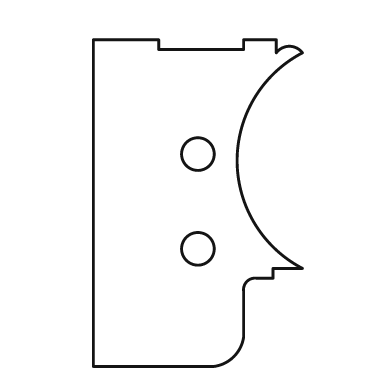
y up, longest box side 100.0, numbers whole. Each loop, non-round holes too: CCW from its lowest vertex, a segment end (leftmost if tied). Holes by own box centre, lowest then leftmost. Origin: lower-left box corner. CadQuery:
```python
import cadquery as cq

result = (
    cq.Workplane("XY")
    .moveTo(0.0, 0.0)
    .lineTo(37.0, 0.0)
    .threePointArc((43.0, 3.0), (46.0, 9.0))
    .lineTo(46.0, 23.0)
    .threePointArc((47.0, 26.0), (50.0, 27.0))
    .lineTo(55.0, 27.0)
    .lineTo(55.0, 30.0)
    .lineTo(64.0, 30.0)
    .threePointArc((44.0, 63.0), (64.0, 96.0))
    .threePointArc((60.0, 98.0), (56.0, 96.0))
    .lineTo(56.0, 100.0)
    .lineTo(46.0, 100.0)
    .lineTo(46.0, 97.0)
    .lineTo(20.0, 97.0)
    .lineTo(20.0, 100.0)
    .lineTo(0.0, 100.0)
    .close()
    .moveTo(32.0, 36.0)
    .circle(5.0)
    .moveTo(32.0, 65.0)
    .circle(5.0)
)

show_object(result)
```